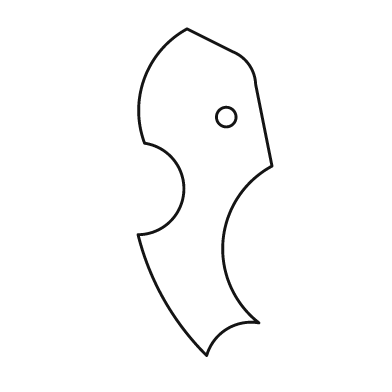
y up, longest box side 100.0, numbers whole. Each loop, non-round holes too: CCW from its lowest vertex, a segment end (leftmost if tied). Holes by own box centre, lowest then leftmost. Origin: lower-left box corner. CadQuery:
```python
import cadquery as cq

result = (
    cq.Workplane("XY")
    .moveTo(21.0, 0.0)
    .threePointArc((27.0, 8.0), (37.0, 10.0))
    .threePointArc((26.0, 35.0), (41.0, 58.0))
    .lineTo(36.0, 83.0)
    .threePointArc((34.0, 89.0), (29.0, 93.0))
    .lineTo(15.0, 100.0)
    .threePointArc((2.0, 85.0), (2.0, 65.0))
    .threePointArc((14.0, 50.0), (0.0, 37.0))
    .threePointArc((8.0, 17.0), (21.0, 0.0))
    .close()
    .moveTo(27.0, 73.0)
    .circle(3.0)
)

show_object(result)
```